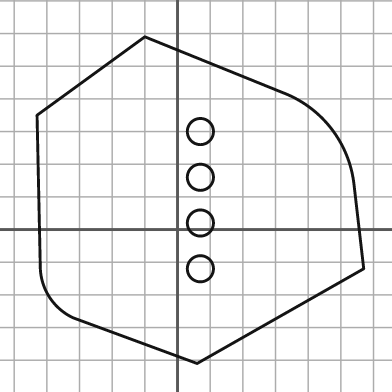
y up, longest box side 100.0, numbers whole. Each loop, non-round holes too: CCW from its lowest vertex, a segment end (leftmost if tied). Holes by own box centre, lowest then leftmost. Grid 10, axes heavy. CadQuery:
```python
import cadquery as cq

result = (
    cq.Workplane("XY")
    .moveTo(6.0, -41.0)
    .lineTo(57.0, -12.0)
    .lineTo(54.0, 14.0)
    .threePointArc((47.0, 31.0), (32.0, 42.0))
    .lineTo(-10.0, 59.0)
    .lineTo(-43.0, 35.0)
    .lineTo(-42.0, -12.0)
    .threePointArc((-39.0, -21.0), (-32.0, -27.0))
    .close()
    .moveTo(7.0, -12.0)
    .circle(4.0)
    .moveTo(7.0, 2.0)
    .circle(4.0)
    .moveTo(7.0, 16.0)
    .circle(4.0)
    .moveTo(7.0, 30.0)
    .circle(4.0)
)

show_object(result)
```